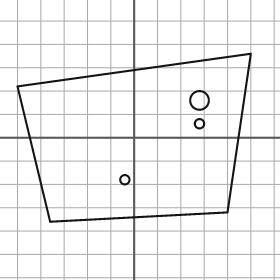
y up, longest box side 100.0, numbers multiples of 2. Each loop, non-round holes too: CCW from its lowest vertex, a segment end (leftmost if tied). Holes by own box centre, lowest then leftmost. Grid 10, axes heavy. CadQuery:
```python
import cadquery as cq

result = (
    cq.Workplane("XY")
    .moveTo(-36.0, -36.0)
    .lineTo(40.0, -32.0)
    .lineTo(50.0, 36.0)
    .lineTo(-50.0, 22.0)
    .close()
    .moveTo(-4.0, -18.0)
    .circle(2.0)
    .moveTo(28.0, 6.0)
    .circle(2.0)
    .moveTo(28.0, 16.0)
    .circle(4.0)
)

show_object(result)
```